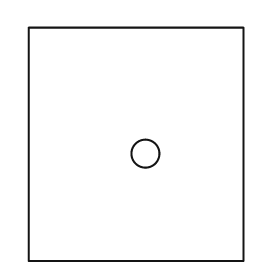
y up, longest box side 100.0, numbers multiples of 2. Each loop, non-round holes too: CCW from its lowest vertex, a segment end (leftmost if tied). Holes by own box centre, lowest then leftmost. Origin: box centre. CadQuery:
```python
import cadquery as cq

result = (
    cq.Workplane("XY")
    .moveTo(-46.0, -50.0)
    .lineTo(46.0, -50.0)
    .lineTo(46.0, 50.0)
    .lineTo(-46.0, 50.0)
    .close()
    .moveTo(4.0, -4.0)
    .circle(6.0)
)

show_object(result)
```